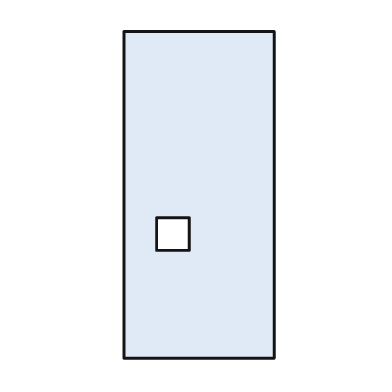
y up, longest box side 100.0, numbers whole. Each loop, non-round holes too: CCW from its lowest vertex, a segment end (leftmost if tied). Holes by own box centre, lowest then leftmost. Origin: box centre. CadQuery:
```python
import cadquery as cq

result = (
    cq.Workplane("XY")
    .moveTo(-23.0, -50.0)
    .lineTo(23.0, -50.0)
    .lineTo(23.0, 50.0)
    .lineTo(-23.0, 50.0)
    .close()
    .moveTo(-13.0, -17.0)
    .lineTo(-3.0, -17.0)
    .lineTo(-3.0, -7.0)
    .lineTo(-13.0, -7.0)
    .close()
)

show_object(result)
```